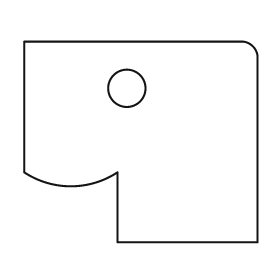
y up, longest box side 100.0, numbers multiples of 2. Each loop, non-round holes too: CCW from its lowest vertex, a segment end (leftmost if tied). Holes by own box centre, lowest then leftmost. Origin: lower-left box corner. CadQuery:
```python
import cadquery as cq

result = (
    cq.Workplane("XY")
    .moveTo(40.0, 0.0)
    .lineTo(100.0, 0.0)
    .lineTo(100.0, 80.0)
    .threePointArc((98.0, 84.0), (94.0, 86.0))
    .lineTo(0.0, 86.0)
    .lineTo(0.0, 30.0)
    .threePointArc((20.0, 24.0), (40.0, 30.0))
    .close()
    .moveTo(44.0, 66.0)
    .circle(8.0)
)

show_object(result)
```